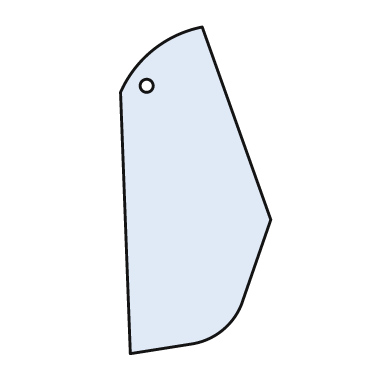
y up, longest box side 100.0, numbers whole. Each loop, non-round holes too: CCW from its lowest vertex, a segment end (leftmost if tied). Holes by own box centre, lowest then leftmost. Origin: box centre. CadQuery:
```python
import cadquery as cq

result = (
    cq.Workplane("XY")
    .moveTo(-20.0, -50.0)
    .lineTo(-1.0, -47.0)
    .threePointArc((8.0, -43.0), (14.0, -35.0))
    .lineTo(23.0, -9.0)
    .lineTo(2.0, 50.0)
    .threePointArc((-13.0, 43.0), (-23.0, 30.0))
    .close()
    .moveTo(-15.0, 32.0)
    .circle(2.0)
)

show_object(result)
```